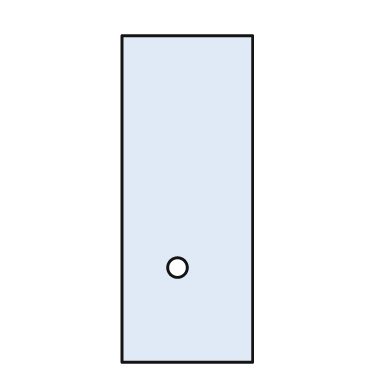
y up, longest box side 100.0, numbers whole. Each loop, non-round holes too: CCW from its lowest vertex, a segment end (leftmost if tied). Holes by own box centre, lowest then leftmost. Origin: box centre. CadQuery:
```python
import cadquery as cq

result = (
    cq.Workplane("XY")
    .moveTo(-20.0, -50.0)
    .lineTo(20.0, -50.0)
    .lineTo(20.0, 50.0)
    .lineTo(-20.0, 50.0)
    .close()
    .moveTo(-3.0, -21.0)
    .circle(3.0)
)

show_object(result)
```